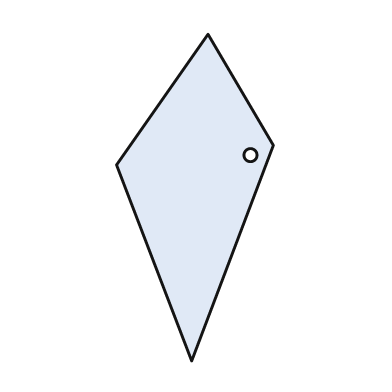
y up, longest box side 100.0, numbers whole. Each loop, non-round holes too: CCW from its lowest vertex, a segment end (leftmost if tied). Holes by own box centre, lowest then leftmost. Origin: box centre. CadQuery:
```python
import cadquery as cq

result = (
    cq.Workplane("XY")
    .moveTo(-1.0, -50.0)
    .lineTo(24.0, 16.0)
    .lineTo(4.0, 50.0)
    .lineTo(-24.0, 10.0)
    .close()
    .moveTo(17.0, 13.0)
    .circle(2.0)
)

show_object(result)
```